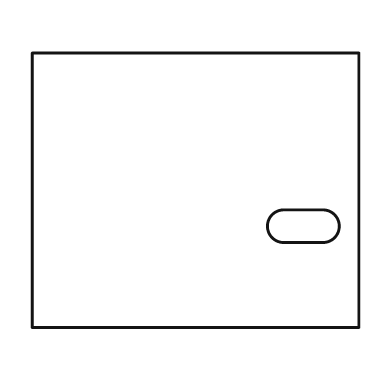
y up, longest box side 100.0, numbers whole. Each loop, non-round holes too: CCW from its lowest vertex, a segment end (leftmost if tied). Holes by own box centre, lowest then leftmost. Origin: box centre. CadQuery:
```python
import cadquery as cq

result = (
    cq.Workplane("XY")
    .moveTo(-50.0, -42.0)
    .lineTo(50.0, -42.0)
    .lineTo(50.0, 42.0)
    .lineTo(-50.0, 42.0)
    .close()
    .moveTo(27.0, -16.0)
    .lineTo(39.0, -16.0)
    .threePointArc((44.0, -11.0), (39.0, -6.0))
    .lineTo(27.0, -6.0)
    .threePointArc((22.0, -11.0), (27.0, -16.0))
    .close()
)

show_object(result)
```